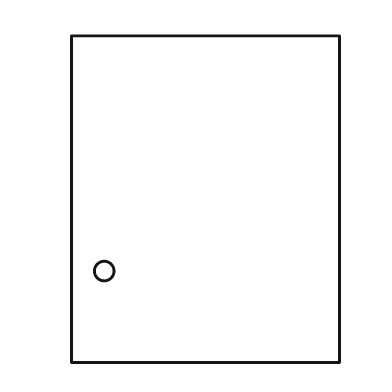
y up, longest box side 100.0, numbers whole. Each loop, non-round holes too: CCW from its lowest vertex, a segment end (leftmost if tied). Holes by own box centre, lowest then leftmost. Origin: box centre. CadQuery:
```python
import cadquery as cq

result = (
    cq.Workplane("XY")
    .moveTo(-41.0, -50.0)
    .lineTo(41.0, -50.0)
    .lineTo(41.0, 50.0)
    .lineTo(-41.0, 50.0)
    .close()
    .moveTo(-31.0, -22.0)
    .circle(3.0)
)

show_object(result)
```